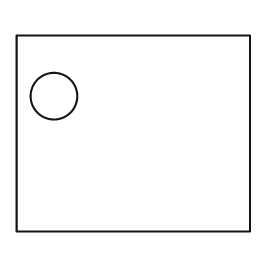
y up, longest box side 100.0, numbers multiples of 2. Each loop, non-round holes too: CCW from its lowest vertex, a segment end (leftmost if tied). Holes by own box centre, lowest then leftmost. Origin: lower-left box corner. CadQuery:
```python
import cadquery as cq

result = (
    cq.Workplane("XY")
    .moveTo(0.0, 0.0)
    .lineTo(100.0, 0.0)
    .lineTo(100.0, 84.0)
    .lineTo(0.0, 84.0)
    .close()
    .moveTo(16.0, 58.0)
    .circle(10.0)
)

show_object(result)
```